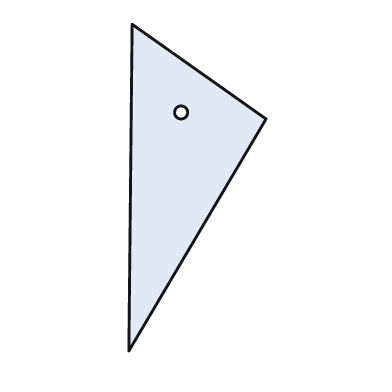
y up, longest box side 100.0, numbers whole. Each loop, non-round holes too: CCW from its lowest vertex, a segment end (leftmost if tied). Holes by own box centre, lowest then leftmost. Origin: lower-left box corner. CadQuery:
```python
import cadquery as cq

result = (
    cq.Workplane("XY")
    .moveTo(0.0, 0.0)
    .lineTo(42.0, 71.0)
    .lineTo(1.0, 100.0)
    .close()
    .moveTo(16.0, 73.0)
    .circle(2.0)
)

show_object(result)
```